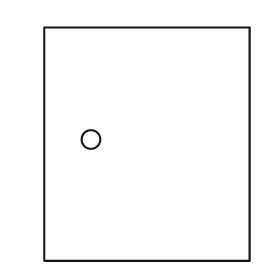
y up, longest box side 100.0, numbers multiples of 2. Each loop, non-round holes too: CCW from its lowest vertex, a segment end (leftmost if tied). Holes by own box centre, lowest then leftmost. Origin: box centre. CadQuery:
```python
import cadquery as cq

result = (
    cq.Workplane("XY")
    .moveTo(-44.0, -50.0)
    .lineTo(44.0, -50.0)
    .lineTo(44.0, 50.0)
    .lineTo(-44.0, 50.0)
    .close()
    .moveTo(-24.0, 2.0)
    .circle(4.0)
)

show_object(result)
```